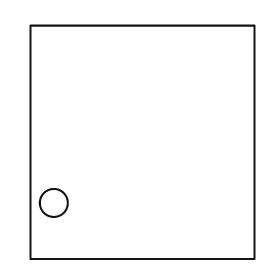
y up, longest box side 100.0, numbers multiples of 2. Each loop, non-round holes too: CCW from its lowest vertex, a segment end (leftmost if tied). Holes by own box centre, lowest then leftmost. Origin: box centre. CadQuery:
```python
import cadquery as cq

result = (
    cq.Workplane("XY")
    .moveTo(-48.0, -50.0)
    .lineTo(48.0, -50.0)
    .lineTo(48.0, 50.0)
    .lineTo(-48.0, 50.0)
    .close()
    .moveTo(-38.0, -26.0)
    .circle(6.0)
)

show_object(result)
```